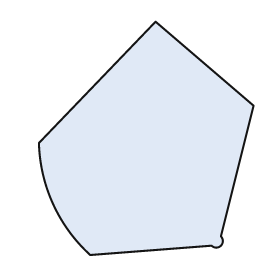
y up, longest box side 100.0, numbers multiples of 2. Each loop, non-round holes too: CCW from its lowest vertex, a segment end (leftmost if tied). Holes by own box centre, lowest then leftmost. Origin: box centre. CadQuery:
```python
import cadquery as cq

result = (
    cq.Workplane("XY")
    .moveTo(-24.0, -50.0)
    .lineTo(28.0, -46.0)
    .threePointArc((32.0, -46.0), (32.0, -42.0))
    .lineTo(46.0, 14.0)
    .lineTo(4.0, 50.0)
    .lineTo(-46.0, -2.0)
    .threePointArc((-40.0, -28.0), (-24.0, -50.0))
    .close()
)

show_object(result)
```